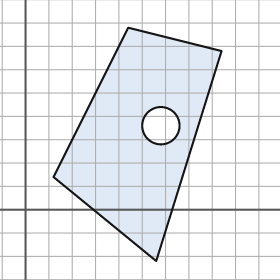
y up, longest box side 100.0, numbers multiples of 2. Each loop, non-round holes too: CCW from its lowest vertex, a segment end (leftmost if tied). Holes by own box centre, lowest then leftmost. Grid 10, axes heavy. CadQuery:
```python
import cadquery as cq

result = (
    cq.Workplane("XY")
    .moveTo(56.0, -22.0)
    .lineTo(84.0, 68.0)
    .lineTo(44.0, 78.0)
    .lineTo(12.0, 14.0)
    .close()
    .moveTo(58.0, 36.0)
    .circle(8.0)
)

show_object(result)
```